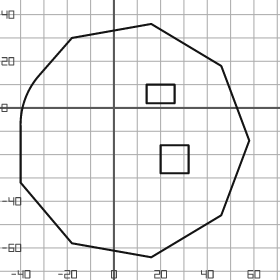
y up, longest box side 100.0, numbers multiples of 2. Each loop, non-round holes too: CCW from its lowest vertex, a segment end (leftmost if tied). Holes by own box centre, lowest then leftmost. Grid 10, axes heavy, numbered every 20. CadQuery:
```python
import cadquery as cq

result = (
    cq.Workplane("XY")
    .moveTo(16.0, -64.0)
    .lineTo(46.0, -46.0)
    .lineTo(58.0, -14.0)
    .lineTo(46.0, 18.0)
    .lineTo(16.0, 36.0)
    .lineTo(-18.0, 30.0)
    .lineTo(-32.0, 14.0)
    .threePointArc((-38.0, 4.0), (-40.0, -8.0))
    .lineTo(-40.0, -32.0)
    .lineTo(-18.0, -58.0)
    .close()
    .moveTo(20.0, -28.0)
    .lineTo(32.0, -28.0)
    .lineTo(32.0, -16.0)
    .lineTo(20.0, -16.0)
    .close()
    .moveTo(14.0, 2.0)
    .lineTo(26.0, 2.0)
    .lineTo(26.0, 10.0)
    .lineTo(14.0, 10.0)
    .close()
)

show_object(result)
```